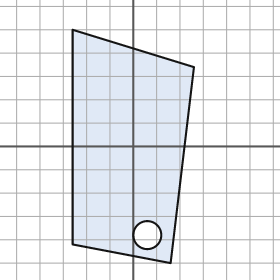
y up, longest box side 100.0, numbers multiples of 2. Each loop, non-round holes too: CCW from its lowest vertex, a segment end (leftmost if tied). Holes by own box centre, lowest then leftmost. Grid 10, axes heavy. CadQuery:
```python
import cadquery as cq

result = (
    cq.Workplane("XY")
    .moveTo(16.0, -50.0)
    .lineTo(26.0, 34.0)
    .lineTo(-26.0, 50.0)
    .lineTo(-26.0, -42.0)
    .close()
    .moveTo(6.0, -38.0)
    .circle(6.0)
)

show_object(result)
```